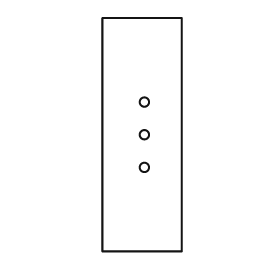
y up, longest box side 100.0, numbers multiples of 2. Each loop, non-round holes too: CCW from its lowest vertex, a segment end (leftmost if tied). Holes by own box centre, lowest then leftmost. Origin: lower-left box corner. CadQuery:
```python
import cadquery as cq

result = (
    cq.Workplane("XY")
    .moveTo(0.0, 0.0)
    .lineTo(34.0, 0.0)
    .lineTo(34.0, 100.0)
    .lineTo(0.0, 100.0)
    .close()
    .moveTo(18.0, 36.0)
    .circle(2.0)
    .moveTo(18.0, 50.0)
    .circle(2.0)
    .moveTo(18.0, 64.0)
    .circle(2.0)
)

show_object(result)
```